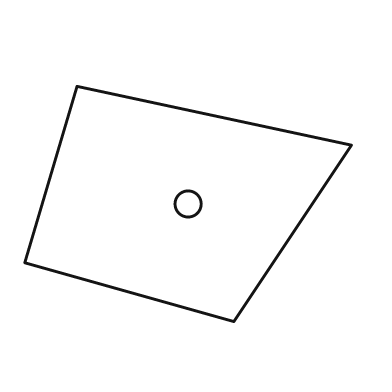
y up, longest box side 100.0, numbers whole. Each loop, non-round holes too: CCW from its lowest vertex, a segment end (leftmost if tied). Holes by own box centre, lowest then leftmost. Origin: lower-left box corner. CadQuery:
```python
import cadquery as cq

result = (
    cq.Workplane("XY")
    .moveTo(64.0, 0.0)
    .lineTo(100.0, 54.0)
    .lineTo(16.0, 72.0)
    .lineTo(0.0, 18.0)
    .close()
    .moveTo(50.0, 36.0)
    .circle(4.0)
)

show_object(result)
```